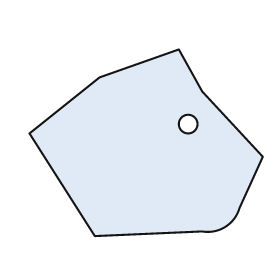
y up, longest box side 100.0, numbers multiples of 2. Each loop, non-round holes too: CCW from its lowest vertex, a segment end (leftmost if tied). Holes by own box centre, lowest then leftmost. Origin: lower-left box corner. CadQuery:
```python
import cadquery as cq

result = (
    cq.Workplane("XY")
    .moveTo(28.0, 0.0)
    .lineTo(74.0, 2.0)
    .threePointArc((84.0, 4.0), (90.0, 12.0))
    .lineTo(100.0, 34.0)
    .lineTo(74.0, 62.0)
    .lineTo(64.0, 80.0)
    .lineTo(30.0, 68.0)
    .lineTo(0.0, 44.0)
    .close()
    .moveTo(68.0, 48.0)
    .circle(4.0)
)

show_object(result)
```